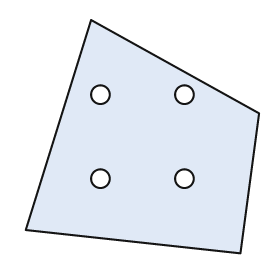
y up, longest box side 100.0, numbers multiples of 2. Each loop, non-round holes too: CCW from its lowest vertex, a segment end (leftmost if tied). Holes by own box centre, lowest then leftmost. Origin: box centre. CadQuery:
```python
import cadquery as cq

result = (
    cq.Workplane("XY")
    .moveTo(42.0, -50.0)
    .lineTo(50.0, 10.0)
    .lineTo(-22.0, 50.0)
    .lineTo(-50.0, -40.0)
    .close()
    .moveTo(-18.0, -18.0)
    .circle(4.0)
    .moveTo(18.0, -18.0)
    .circle(4.0)
    .moveTo(-18.0, 18.0)
    .circle(4.0)
    .moveTo(18.0, 18.0)
    .circle(4.0)
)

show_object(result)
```